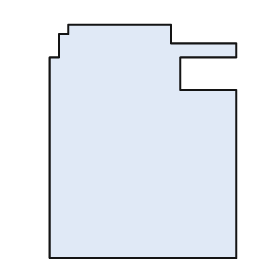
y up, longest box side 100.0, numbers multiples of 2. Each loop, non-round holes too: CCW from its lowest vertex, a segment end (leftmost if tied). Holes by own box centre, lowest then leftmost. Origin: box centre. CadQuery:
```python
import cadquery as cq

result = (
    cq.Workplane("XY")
    .moveTo(-40.0, -50.0)
    .lineTo(40.0, -50.0)
    .lineTo(40.0, 22.0)
    .lineTo(16.0, 22.0)
    .lineTo(16.0, 36.0)
    .lineTo(40.0, 36.0)
    .lineTo(40.0, 42.0)
    .lineTo(12.0, 42.0)
    .lineTo(12.0, 50.0)
    .lineTo(-32.0, 50.0)
    .lineTo(-32.0, 46.0)
    .lineTo(-36.0, 46.0)
    .lineTo(-36.0, 36.0)
    .lineTo(-40.0, 36.0)
    .close()
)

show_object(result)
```